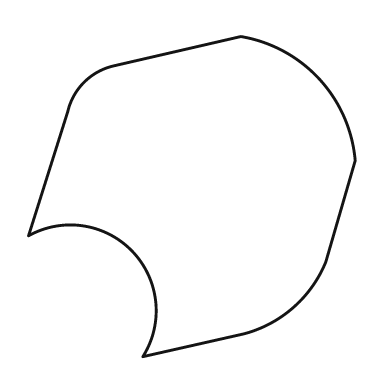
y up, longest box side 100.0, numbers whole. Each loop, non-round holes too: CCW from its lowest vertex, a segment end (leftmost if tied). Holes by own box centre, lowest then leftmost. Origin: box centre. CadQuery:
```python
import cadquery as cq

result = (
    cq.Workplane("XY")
    .moveTo(-15.0, -49.0)
    .lineTo(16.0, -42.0)
    .threePointArc((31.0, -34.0), (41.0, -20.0))
    .lineTo(50.0, 11.0)
    .threePointArc((39.0, 36.0), (15.0, 49.0))
    .lineTo(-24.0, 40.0)
    .threePointArc((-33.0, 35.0), (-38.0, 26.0))
    .lineTo(-50.0, -12.0)
    .threePointArc((-18.0, -17.0), (-15.0, -49.0))
    .close()
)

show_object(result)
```